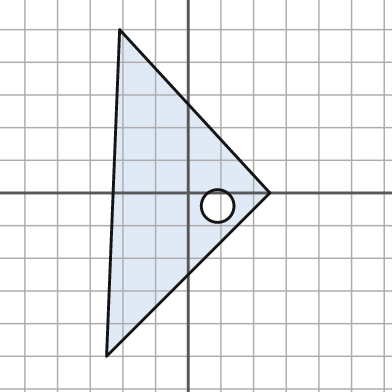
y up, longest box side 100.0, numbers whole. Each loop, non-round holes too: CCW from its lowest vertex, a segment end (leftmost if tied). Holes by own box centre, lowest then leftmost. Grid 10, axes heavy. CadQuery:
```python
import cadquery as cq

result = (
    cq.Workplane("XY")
    .moveTo(-25.0, -50.0)
    .lineTo(25.0, 0.0)
    .lineTo(-21.0, 50.0)
    .close()
    .moveTo(9.0, -4.0)
    .circle(5.0)
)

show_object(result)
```